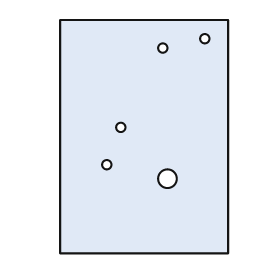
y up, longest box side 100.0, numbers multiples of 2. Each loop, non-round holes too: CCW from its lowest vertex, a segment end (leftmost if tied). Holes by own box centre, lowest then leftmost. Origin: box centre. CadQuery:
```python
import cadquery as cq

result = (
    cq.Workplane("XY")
    .moveTo(-36.0, -50.0)
    .lineTo(36.0, -50.0)
    .lineTo(36.0, 50.0)
    .lineTo(-36.0, 50.0)
    .close()
    .moveTo(10.0, -18.0)
    .circle(4.0)
    .moveTo(-16.0, -12.0)
    .circle(2.0)
    .moveTo(-10.0, 4.0)
    .circle(2.0)
    .moveTo(8.0, 38.0)
    .circle(2.0)
    .moveTo(26.0, 42.0)
    .circle(2.0)
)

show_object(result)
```